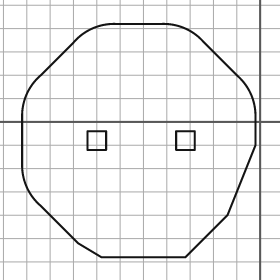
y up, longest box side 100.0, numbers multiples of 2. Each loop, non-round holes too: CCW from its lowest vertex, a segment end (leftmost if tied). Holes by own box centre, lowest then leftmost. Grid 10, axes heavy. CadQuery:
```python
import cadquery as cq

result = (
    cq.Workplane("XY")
    .moveTo(-68.0, -58.0)
    .lineTo(-32.0, -58.0)
    .lineTo(-14.0, -40.0)
    .lineTo(-2.0, -10.0)
    .lineTo(-2.0, 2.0)
    .threePointArc((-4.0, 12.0), (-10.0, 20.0))
    .lineTo(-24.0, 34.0)
    .threePointArc((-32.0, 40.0), (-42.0, 42.0))
    .lineTo(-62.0, 42.0)
    .threePointArc((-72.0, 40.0), (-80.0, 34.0))
    .lineTo(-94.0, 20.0)
    .threePointArc((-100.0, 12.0), (-102.0, 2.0))
    .lineTo(-102.0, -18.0)
    .threePointArc((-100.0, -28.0), (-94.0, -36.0))
    .lineTo(-78.0, -52.0)
    .close()
    .moveTo(-74.0, -12.0)
    .lineTo(-66.0, -12.0)
    .lineTo(-66.0, -4.0)
    .lineTo(-74.0, -4.0)
    .close()
    .moveTo(-36.0, -12.0)
    .lineTo(-28.0, -12.0)
    .lineTo(-28.0, -4.0)
    .lineTo(-36.0, -4.0)
    .close()
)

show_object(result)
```